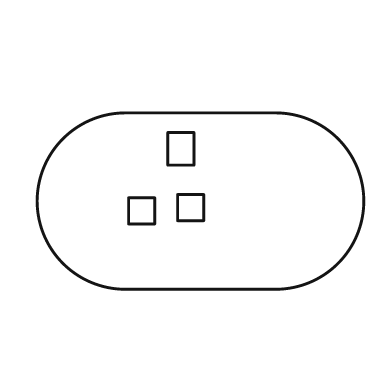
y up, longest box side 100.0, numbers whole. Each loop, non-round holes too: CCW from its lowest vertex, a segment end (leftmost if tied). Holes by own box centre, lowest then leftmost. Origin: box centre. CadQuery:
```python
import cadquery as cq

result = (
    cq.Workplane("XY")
    .moveTo(-23.0, -27.0)
    .lineTo(23.0, -27.0)
    .threePointArc((50.0, 0.0), (23.0, 27.0))
    .lineTo(-23.0, 27.0)
    .threePointArc((-50.0, 0.0), (-23.0, -27.0))
    .close()
    .moveTo(-22.0, -7.0)
    .lineTo(-14.0, -7.0)
    .lineTo(-14.0, 1.0)
    .lineTo(-22.0, 1.0)
    .close()
    .moveTo(-7.0, -6.0)
    .lineTo(1.0, -6.0)
    .lineTo(1.0, 2.0)
    .lineTo(-7.0, 2.0)
    .close()
    .moveTo(-10.0, 11.0)
    .lineTo(-2.0, 11.0)
    .lineTo(-2.0, 21.0)
    .lineTo(-10.0, 21.0)
    .close()
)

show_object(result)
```